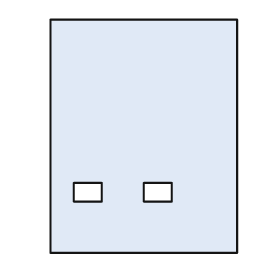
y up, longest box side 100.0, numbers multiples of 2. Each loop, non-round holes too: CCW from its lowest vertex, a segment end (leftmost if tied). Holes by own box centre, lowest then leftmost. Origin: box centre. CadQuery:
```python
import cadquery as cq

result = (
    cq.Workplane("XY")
    .moveTo(-40.0, -50.0)
    .lineTo(40.0, -50.0)
    .lineTo(40.0, 50.0)
    .lineTo(-40.0, 50.0)
    .close()
    .moveTo(-30.0, -28.0)
    .lineTo(-18.0, -28.0)
    .lineTo(-18.0, -20.0)
    .lineTo(-30.0, -20.0)
    .close()
    .moveTo(0.0, -28.0)
    .lineTo(12.0, -28.0)
    .lineTo(12.0, -20.0)
    .lineTo(0.0, -20.0)
    .close()
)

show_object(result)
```